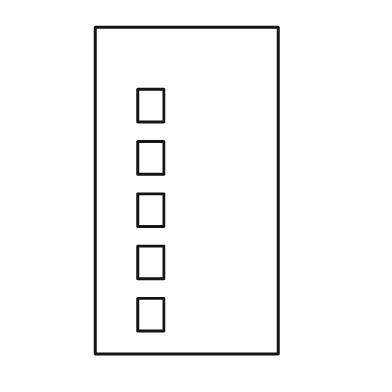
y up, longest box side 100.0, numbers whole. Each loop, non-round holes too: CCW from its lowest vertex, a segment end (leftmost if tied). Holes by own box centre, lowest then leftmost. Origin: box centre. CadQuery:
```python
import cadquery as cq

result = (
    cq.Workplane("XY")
    .moveTo(-28.0, -50.0)
    .lineTo(28.0, -50.0)
    .lineTo(28.0, 50.0)
    .lineTo(-28.0, 50.0)
    .close()
    .moveTo(-15.0, -43.0)
    .lineTo(-7.0, -43.0)
    .lineTo(-7.0, -33.0)
    .lineTo(-15.0, -33.0)
    .close()
    .moveTo(-15.0, -27.0)
    .lineTo(-7.0, -27.0)
    .lineTo(-7.0, -17.0)
    .lineTo(-15.0, -17.0)
    .close()
    .moveTo(-15.0, -11.0)
    .lineTo(-7.0, -11.0)
    .lineTo(-7.0, -1.0)
    .lineTo(-15.0, -1.0)
    .close()
    .moveTo(-15.0, 5.0)
    .lineTo(-7.0, 5.0)
    .lineTo(-7.0, 15.0)
    .lineTo(-15.0, 15.0)
    .close()
    .moveTo(-15.0, 21.0)
    .lineTo(-7.0, 21.0)
    .lineTo(-7.0, 31.0)
    .lineTo(-15.0, 31.0)
    .close()
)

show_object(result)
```